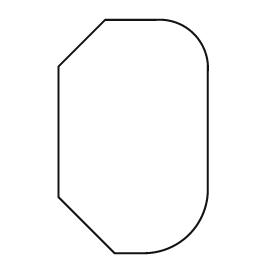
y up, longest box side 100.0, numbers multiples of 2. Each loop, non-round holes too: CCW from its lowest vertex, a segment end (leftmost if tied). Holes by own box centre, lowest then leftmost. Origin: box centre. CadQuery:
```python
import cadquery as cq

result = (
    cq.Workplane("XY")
    .moveTo(-8.0, -50.0)
    .lineTo(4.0, -50.0)
    .threePointArc((24.0, -42.0), (32.0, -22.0))
    .lineTo(32.0, 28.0)
    .threePointArc((26.0, 44.0), (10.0, 50.0))
    .lineTo(-12.0, 50.0)
    .lineTo(-32.0, 30.0)
    .lineTo(-32.0, -26.0)
    .close()
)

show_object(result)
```